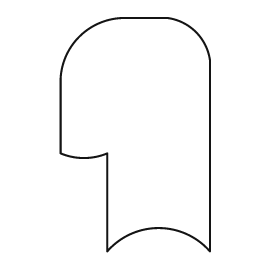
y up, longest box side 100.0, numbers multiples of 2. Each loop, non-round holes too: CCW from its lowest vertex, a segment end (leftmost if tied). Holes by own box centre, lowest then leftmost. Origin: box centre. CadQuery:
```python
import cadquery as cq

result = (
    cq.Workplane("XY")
    .moveTo(-12.0, -50.0)
    .threePointArc((10.0, -40.0), (32.0, -50.0))
    .lineTo(32.0, 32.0)
    .threePointArc((26.0, 44.0), (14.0, 50.0))
    .lineTo(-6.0, 50.0)
    .threePointArc((-24.0, 42.0), (-32.0, 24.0))
    .lineTo(-32.0, -8.0)
    .threePointArc((-22.0, -10.0), (-12.0, -8.0))
    .close()
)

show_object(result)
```